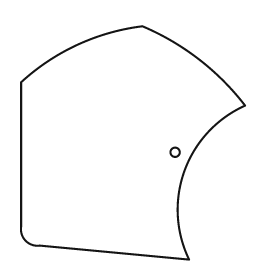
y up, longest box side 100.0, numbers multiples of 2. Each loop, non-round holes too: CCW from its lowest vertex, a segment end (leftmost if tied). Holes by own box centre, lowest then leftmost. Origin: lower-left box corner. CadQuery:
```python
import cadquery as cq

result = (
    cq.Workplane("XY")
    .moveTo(72.0, 0.0)
    .threePointArc((70.0, 38.0), (96.0, 66.0))
    .threePointArc((76.0, 86.0), (52.0, 100.0))
    .threePointArc((24.0, 92.0), (0.0, 76.0))
    .lineTo(0.0, 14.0)
    .threePointArc((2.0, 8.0), (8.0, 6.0))
    .close()
    .moveTo(66.0, 46.0)
    .circle(2.0)
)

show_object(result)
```